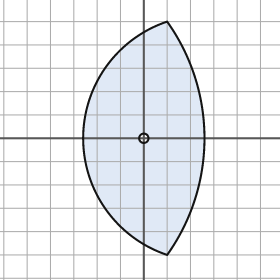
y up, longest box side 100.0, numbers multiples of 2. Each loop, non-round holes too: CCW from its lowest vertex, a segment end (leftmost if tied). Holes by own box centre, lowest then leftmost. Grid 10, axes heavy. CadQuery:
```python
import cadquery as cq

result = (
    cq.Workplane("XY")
    .moveTo(10.0, -50.0)
    .threePointArc((26.0, 0.0), (10.0, 50.0))
    .threePointArc((-26.0, 0.0), (10.0, -50.0))
    .close()
    .moveTo(0.0, 0.0)
    .circle(2.0)
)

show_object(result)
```